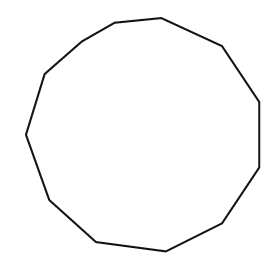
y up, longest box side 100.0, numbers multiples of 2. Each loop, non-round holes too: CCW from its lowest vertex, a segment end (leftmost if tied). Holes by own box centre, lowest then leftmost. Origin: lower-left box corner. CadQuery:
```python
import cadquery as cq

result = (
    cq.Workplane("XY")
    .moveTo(60.0, 0.0)
    .lineTo(84.0, 12.0)
    .lineTo(100.0, 36.0)
    .lineTo(100.0, 64.0)
    .lineTo(84.0, 88.0)
    .lineTo(58.0, 100.0)
    .lineTo(38.0, 98.0)
    .lineTo(24.0, 90.0)
    .lineTo(8.0, 76.0)
    .lineTo(0.0, 50.0)
    .lineTo(10.0, 22.0)
    .lineTo(30.0, 4.0)
    .close()
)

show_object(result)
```